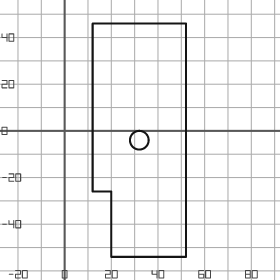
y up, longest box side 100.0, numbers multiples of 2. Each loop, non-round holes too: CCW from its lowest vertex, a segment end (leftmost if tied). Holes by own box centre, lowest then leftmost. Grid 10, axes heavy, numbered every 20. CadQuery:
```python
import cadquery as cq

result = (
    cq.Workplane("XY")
    .moveTo(20.0, -54.0)
    .lineTo(52.0, -54.0)
    .lineTo(52.0, 46.0)
    .lineTo(12.0, 46.0)
    .lineTo(12.0, -26.0)
    .lineTo(20.0, -26.0)
    .close()
    .moveTo(32.0, -4.0)
    .circle(4.0)
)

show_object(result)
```